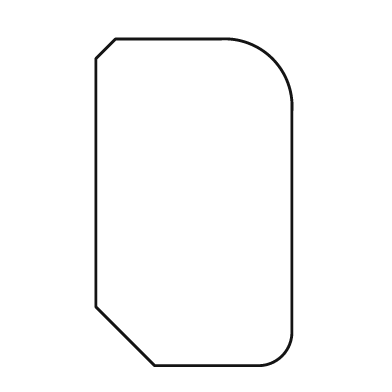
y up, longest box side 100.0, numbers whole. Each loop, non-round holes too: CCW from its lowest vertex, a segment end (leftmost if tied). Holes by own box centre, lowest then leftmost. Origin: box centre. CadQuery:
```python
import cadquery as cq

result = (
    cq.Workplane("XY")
    .moveTo(-12.0, -50.0)
    .lineTo(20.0, -50.0)
    .threePointArc((27.0, -47.0), (30.0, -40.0))
    .lineTo(30.0, 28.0)
    .threePointArc((24.0, 44.0), (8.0, 50.0))
    .lineTo(-24.0, 50.0)
    .lineTo(-30.0, 44.0)
    .lineTo(-30.0, -32.0)
    .close()
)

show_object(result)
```